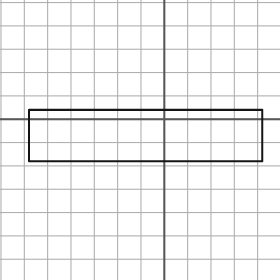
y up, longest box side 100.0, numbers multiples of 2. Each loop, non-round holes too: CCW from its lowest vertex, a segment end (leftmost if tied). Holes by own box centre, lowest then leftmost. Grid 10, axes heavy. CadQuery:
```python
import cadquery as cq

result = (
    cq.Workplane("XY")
    .moveTo(-58.0, -18.0)
    .lineTo(42.0, -18.0)
    .lineTo(42.0, 4.0)
    .lineTo(-58.0, 4.0)
    .close()
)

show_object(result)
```